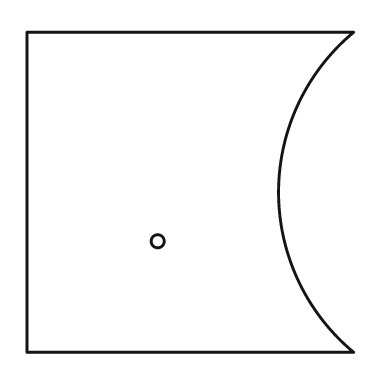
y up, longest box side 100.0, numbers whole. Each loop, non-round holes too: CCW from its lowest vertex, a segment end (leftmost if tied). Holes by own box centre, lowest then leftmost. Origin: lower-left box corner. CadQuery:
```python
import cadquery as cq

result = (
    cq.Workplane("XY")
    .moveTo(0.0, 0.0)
    .lineTo(100.0, 0.0)
    .threePointArc((77.0, 49.0), (100.0, 98.0))
    .lineTo(0.0, 98.0)
    .close()
    .moveTo(40.0, 34.0)
    .circle(2.0)
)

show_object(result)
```